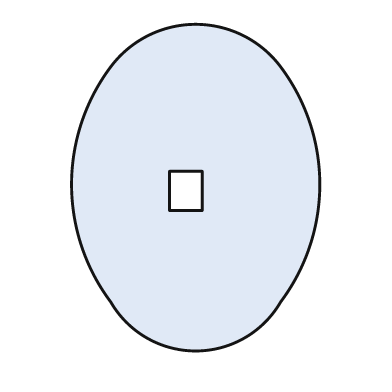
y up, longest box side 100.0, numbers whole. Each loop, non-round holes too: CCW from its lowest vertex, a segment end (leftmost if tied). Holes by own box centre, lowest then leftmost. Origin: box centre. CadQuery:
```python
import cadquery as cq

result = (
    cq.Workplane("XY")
    .moveTo(-26.0, -35.0)
    .threePointArc((0.0, -50.0), (26.0, -35.0))
    .threePointArc((38.0, 1.0), (26.0, 37.0))
    .threePointArc((0.0, 50.0), (-26.0, 37.0))
    .threePointArc((-38.0, 1.0), (-26.0, -35.0))
    .close()
    .moveTo(-8.0, -7.0)
    .lineTo(2.0, -7.0)
    .lineTo(2.0, 5.0)
    .lineTo(-8.0, 5.0)
    .close()
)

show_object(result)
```